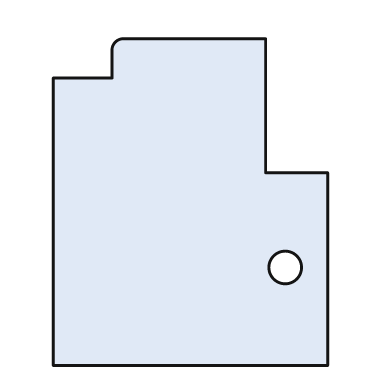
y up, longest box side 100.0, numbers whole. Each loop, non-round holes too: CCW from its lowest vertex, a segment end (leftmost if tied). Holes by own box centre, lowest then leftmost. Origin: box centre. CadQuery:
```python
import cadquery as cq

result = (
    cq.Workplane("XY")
    .moveTo(-42.0, -50.0)
    .lineTo(42.0, -50.0)
    .lineTo(42.0, 9.0)
    .lineTo(23.0, 9.0)
    .lineTo(23.0, 50.0)
    .lineTo(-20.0, 50.0)
    .threePointArc((-23.0, 49.0), (-24.0, 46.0))
    .lineTo(-24.0, 38.0)
    .lineTo(-42.0, 38.0)
    .close()
    .moveTo(29.0, -20.0)
    .circle(5.0)
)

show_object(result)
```